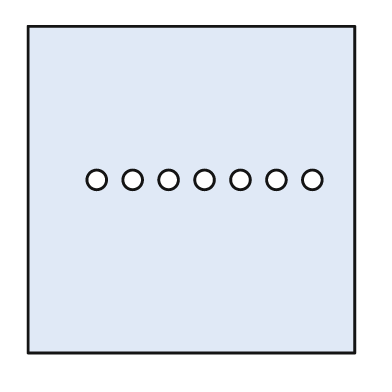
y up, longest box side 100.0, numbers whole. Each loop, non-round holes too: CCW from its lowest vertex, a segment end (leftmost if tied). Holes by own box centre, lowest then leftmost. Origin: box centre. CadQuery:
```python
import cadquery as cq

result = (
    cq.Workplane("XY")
    .moveTo(-50.0, -50.0)
    .lineTo(50.0, -50.0)
    .lineTo(50.0, 50.0)
    .lineTo(-50.0, 50.0)
    .close()
    .moveTo(-29.0, 3.0)
    .circle(3.0)
    .moveTo(-18.0, 3.0)
    .circle(3.0)
    .moveTo(-7.0, 3.0)
    .circle(3.0)
    .moveTo(4.0, 3.0)
    .circle(3.0)
    .moveTo(15.0, 3.0)
    .circle(3.0)
    .moveTo(26.0, 3.0)
    .circle(3.0)
    .moveTo(37.0, 3.0)
    .circle(3.0)
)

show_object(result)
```